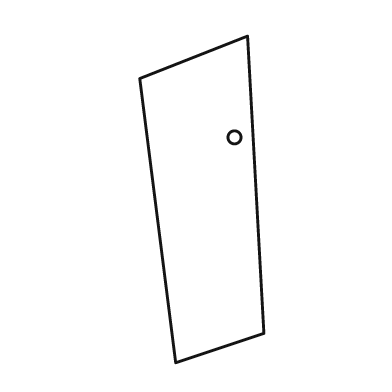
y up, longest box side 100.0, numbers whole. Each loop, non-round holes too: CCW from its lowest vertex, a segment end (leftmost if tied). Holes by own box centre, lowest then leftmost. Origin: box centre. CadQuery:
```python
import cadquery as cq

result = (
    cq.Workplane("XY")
    .moveTo(-8.0, -50.0)
    .lineTo(19.0, -41.0)
    .lineTo(14.0, 50.0)
    .lineTo(-19.0, 37.0)
    .close()
    .moveTo(10.0, 19.0)
    .circle(2.0)
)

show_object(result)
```